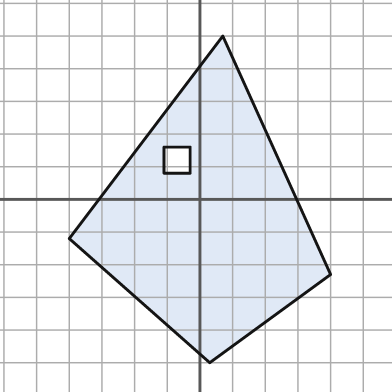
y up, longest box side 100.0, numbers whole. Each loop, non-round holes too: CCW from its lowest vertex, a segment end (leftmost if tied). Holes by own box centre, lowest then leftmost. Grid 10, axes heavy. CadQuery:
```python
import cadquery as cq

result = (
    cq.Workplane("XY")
    .moveTo(3.0, -50.0)
    .lineTo(40.0, -23.0)
    .lineTo(7.0, 50.0)
    .lineTo(-40.0, -12.0)
    .close()
    .moveTo(-11.0, 8.0)
    .lineTo(-3.0, 8.0)
    .lineTo(-3.0, 16.0)
    .lineTo(-11.0, 16.0)
    .close()
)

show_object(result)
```